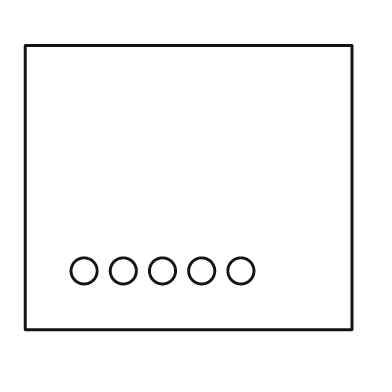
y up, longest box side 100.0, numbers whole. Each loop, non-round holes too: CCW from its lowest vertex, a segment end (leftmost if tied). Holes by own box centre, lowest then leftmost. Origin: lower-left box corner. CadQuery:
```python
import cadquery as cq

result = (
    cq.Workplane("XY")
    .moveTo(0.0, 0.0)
    .lineTo(100.0, 0.0)
    .lineTo(100.0, 87.0)
    .lineTo(0.0, 87.0)
    .close()
    .moveTo(18.0, 18.0)
    .circle(4.0)
    .moveTo(30.0, 18.0)
    .circle(4.0)
    .moveTo(42.0, 18.0)
    .circle(4.0)
    .moveTo(54.0, 18.0)
    .circle(4.0)
    .moveTo(66.0, 18.0)
    .circle(4.0)
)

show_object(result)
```